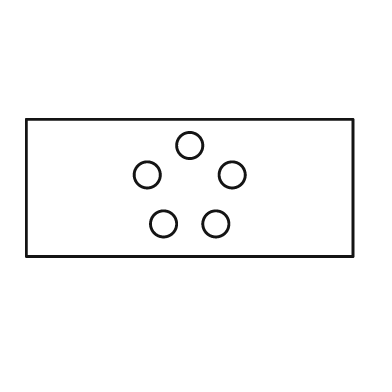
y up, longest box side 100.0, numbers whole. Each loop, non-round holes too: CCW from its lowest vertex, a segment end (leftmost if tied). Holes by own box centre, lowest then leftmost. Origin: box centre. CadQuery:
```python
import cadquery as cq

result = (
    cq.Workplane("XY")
    .moveTo(-50.0, -21.0)
    .lineTo(50.0, -21.0)
    .lineTo(50.0, 21.0)
    .lineTo(-50.0, 21.0)
    .close()
    .moveTo(-8.0, -11.0)
    .circle(4.0)
    .moveTo(8.0, -11.0)
    .circle(4.0)
    .moveTo(-13.0, 4.0)
    .circle(4.0)
    .moveTo(13.0, 4.0)
    .circle(4.0)
    .moveTo(0.0, 13.0)
    .circle(4.0)
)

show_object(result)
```